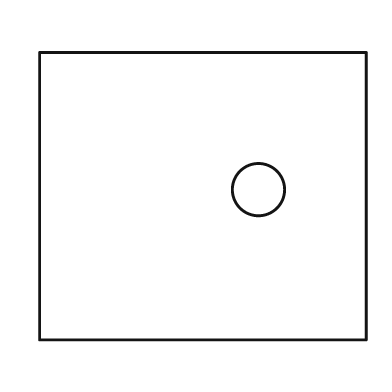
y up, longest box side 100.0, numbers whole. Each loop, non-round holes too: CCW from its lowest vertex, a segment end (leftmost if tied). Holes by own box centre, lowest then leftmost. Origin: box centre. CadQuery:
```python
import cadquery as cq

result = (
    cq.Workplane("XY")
    .moveTo(-50.0, -44.0)
    .lineTo(50.0, -44.0)
    .lineTo(50.0, 44.0)
    .lineTo(-50.0, 44.0)
    .close()
    .moveTo(17.0, 2.0)
    .circle(8.0)
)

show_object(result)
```